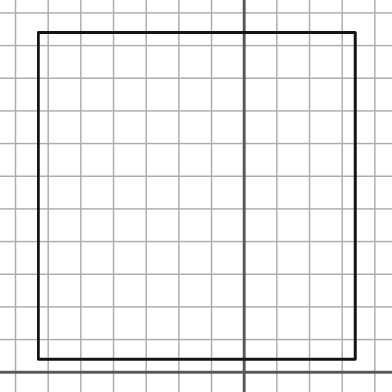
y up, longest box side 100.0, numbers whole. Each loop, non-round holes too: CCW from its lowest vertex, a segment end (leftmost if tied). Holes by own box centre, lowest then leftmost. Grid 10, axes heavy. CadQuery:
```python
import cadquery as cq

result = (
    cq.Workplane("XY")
    .moveTo(-63.0, 4.0)
    .lineTo(34.0, 4.0)
    .lineTo(34.0, 104.0)
    .lineTo(-63.0, 104.0)
    .close()
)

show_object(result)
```